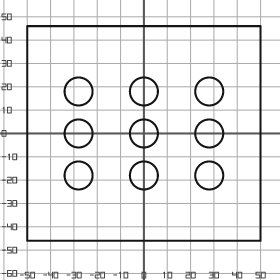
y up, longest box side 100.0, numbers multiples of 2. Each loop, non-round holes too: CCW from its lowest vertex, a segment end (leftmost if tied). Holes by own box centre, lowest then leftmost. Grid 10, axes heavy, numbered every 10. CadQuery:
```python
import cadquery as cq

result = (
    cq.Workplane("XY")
    .moveTo(-50.0, -46.0)
    .lineTo(50.0, -46.0)
    .lineTo(50.0, 46.0)
    .lineTo(-50.0, 46.0)
    .close()
    .moveTo(-28.0, -18.0)
    .circle(6.0)
    .moveTo(0.0, -18.0)
    .circle(6.0)
    .moveTo(28.0, -18.0)
    .circle(6.0)
    .moveTo(-28.0, 0.0)
    .circle(6.0)
    .moveTo(0.0, 0.0)
    .circle(6.0)
    .moveTo(28.0, 0.0)
    .circle(6.0)
    .moveTo(-28.0, 18.0)
    .circle(6.0)
    .moveTo(0.0, 18.0)
    .circle(6.0)
    .moveTo(28.0, 18.0)
    .circle(6.0)
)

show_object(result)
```